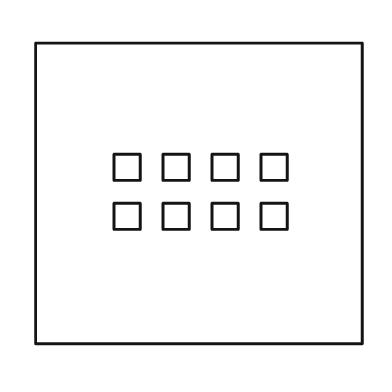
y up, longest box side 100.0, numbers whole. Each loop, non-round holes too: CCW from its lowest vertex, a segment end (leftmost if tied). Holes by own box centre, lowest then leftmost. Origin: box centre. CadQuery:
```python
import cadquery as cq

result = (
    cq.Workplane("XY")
    .moveTo(-50.0, -46.0)
    .lineTo(50.0, -46.0)
    .lineTo(50.0, 46.0)
    .lineTo(-50.0, 46.0)
    .close()
    .moveTo(-26.0, -11.0)
    .lineTo(-18.0, -11.0)
    .lineTo(-18.0, -3.0)
    .lineTo(-26.0, -3.0)
    .close()
    .moveTo(-11.0, -11.0)
    .lineTo(-3.0, -11.0)
    .lineTo(-3.0, -3.0)
    .lineTo(-11.0, -3.0)
    .close()
    .moveTo(4.0, -11.0)
    .lineTo(12.0, -11.0)
    .lineTo(12.0, -3.0)
    .lineTo(4.0, -3.0)
    .close()
    .moveTo(19.0, -11.0)
    .lineTo(27.0, -11.0)
    .lineTo(27.0, -3.0)
    .lineTo(19.0, -3.0)
    .close()
    .moveTo(-26.0, 4.0)
    .lineTo(-18.0, 4.0)
    .lineTo(-18.0, 12.0)
    .lineTo(-26.0, 12.0)
    .close()
    .moveTo(-11.0, 4.0)
    .lineTo(-3.0, 4.0)
    .lineTo(-3.0, 12.0)
    .lineTo(-11.0, 12.0)
    .close()
    .moveTo(4.0, 4.0)
    .lineTo(12.0, 4.0)
    .lineTo(12.0, 12.0)
    .lineTo(4.0, 12.0)
    .close()
    .moveTo(19.0, 4.0)
    .lineTo(27.0, 4.0)
    .lineTo(27.0, 12.0)
    .lineTo(19.0, 12.0)
    .close()
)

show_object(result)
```